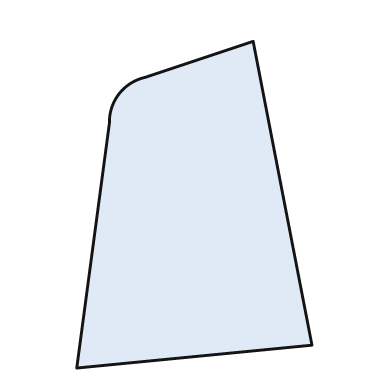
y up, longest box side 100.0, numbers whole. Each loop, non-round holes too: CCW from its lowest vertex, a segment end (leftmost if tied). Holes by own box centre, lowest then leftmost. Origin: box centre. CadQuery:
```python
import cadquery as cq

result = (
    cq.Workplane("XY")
    .moveTo(-36.0, -50.0)
    .lineTo(36.0, -43.0)
    .lineTo(18.0, 50.0)
    .lineTo(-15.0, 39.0)
    .threePointArc((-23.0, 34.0), (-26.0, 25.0))
    .close()
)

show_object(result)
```